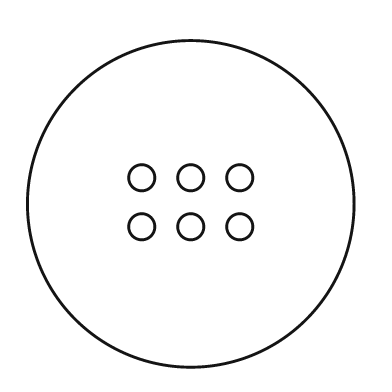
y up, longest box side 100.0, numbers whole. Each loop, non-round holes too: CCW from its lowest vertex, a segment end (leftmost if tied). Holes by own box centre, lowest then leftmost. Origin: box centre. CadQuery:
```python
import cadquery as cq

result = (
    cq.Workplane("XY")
    .moveTo(0.0, 0.0)
    .circle(50.0)
    .moveTo(-15.0, -7.0)
    .circle(4.0)
    .moveTo(0.0, -7.0)
    .circle(4.0)
    .moveTo(15.0, -7.0)
    .circle(4.0)
    .moveTo(-15.0, 8.0)
    .circle(4.0)
    .moveTo(0.0, 8.0)
    .circle(4.0)
    .moveTo(15.0, 8.0)
    .circle(4.0)
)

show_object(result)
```